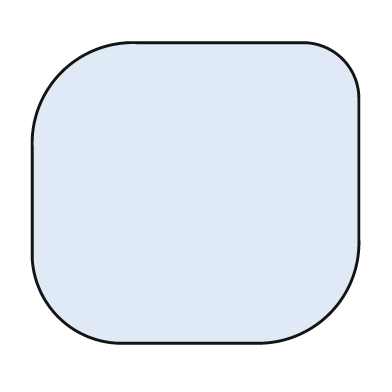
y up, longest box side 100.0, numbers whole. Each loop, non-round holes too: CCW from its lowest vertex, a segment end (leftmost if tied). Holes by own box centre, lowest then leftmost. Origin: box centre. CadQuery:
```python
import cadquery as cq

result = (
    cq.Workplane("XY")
    .moveTo(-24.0, -46.0)
    .lineTo(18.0, -46.0)
    .threePointArc((41.0, -37.0), (50.0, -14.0))
    .lineTo(50.0, 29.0)
    .threePointArc((45.0, 41.0), (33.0, 46.0))
    .lineTo(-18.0, 46.0)
    .threePointArc((-41.0, 37.0), (-50.0, 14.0))
    .lineTo(-50.0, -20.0)
    .threePointArc((-42.0, -38.0), (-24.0, -46.0))
    .close()
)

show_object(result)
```